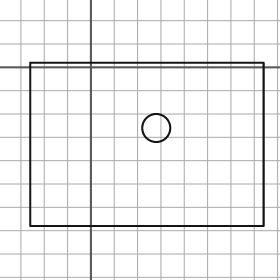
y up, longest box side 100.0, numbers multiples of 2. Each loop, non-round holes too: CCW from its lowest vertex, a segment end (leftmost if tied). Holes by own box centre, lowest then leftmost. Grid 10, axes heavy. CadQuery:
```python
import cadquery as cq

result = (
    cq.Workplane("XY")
    .moveTo(-26.0, -68.0)
    .lineTo(74.0, -68.0)
    .lineTo(74.0, 2.0)
    .lineTo(-26.0, 2.0)
    .close()
    .moveTo(28.0, -26.0)
    .circle(6.0)
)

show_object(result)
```